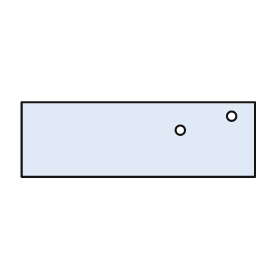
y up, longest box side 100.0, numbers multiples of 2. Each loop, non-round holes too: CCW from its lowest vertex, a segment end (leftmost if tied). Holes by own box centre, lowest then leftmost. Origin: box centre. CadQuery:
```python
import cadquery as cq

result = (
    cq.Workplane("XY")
    .moveTo(-50.0, -16.0)
    .lineTo(50.0, -16.0)
    .lineTo(50.0, 16.0)
    .lineTo(-50.0, 16.0)
    .close()
    .moveTo(18.0, 4.0)
    .circle(2.0)
    .moveTo(40.0, 10.0)
    .circle(2.0)
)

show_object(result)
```